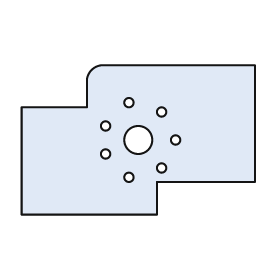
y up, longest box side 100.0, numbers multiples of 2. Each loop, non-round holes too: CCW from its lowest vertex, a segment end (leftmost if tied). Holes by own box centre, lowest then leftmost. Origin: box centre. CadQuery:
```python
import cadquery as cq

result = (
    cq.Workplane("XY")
    .moveTo(-50.0, -32.0)
    .lineTo(8.0, -32.0)
    .lineTo(8.0, -18.0)
    .lineTo(50.0, -18.0)
    .lineTo(50.0, 32.0)
    .lineTo(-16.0, 32.0)
    .threePointArc((-20.0, 30.0), (-22.0, 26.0))
    .lineTo(-22.0, 14.0)
    .lineTo(-50.0, 14.0)
    .close()
    .moveTo(-4.0, -16.0)
    .circle(2.0)
    .moveTo(10.0, -12.0)
    .circle(2.0)
    .moveTo(-14.0, -6.0)
    .circle(2.0)
    .moveTo(0.0, 0.0)
    .circle(6.0)
    .moveTo(16.0, 0.0)
    .circle(2.0)
    .moveTo(-14.0, 6.0)
    .circle(2.0)
    .moveTo(10.0, 12.0)
    .circle(2.0)
    .moveTo(-4.0, 16.0)
    .circle(2.0)
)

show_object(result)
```